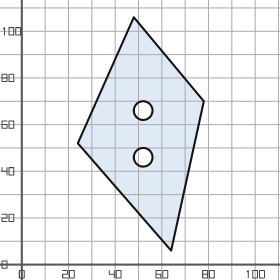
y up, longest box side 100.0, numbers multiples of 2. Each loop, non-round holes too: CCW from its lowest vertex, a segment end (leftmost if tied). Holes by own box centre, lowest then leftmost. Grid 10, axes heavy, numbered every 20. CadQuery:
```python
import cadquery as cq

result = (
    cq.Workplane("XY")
    .moveTo(64.0, 6.0)
    .lineTo(78.0, 70.0)
    .lineTo(48.0, 106.0)
    .lineTo(24.0, 52.0)
    .close()
    .moveTo(52.0, 46.0)
    .circle(4.0)
    .moveTo(52.0, 66.0)
    .circle(4.0)
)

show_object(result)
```